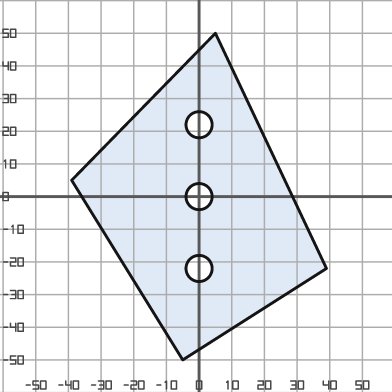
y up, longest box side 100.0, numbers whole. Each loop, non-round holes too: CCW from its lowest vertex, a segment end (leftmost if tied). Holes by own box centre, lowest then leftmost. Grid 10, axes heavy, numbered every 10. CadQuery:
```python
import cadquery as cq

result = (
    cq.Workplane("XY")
    .moveTo(-5.0, -50.0)
    .lineTo(39.0, -22.0)
    .lineTo(5.0, 50.0)
    .lineTo(-39.0, 5.0)
    .close()
    .moveTo(0.0, -22.0)
    .circle(4.0)
    .moveTo(0.0, 0.0)
    .circle(4.0)
    .moveTo(0.0, 22.0)
    .circle(4.0)
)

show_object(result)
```